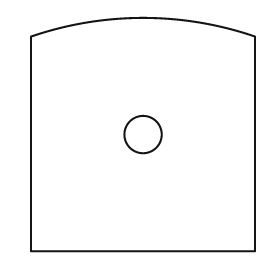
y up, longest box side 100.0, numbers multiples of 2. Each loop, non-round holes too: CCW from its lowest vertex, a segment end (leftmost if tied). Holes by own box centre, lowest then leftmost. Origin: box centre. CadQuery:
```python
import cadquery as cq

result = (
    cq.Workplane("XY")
    .moveTo(-48.0, -50.0)
    .lineTo(48.0, -50.0)
    .lineTo(48.0, 42.0)
    .threePointArc((0.0, 50.0), (-48.0, 42.0))
    .close()
    .moveTo(0.0, 0.0)
    .circle(8.0)
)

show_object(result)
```